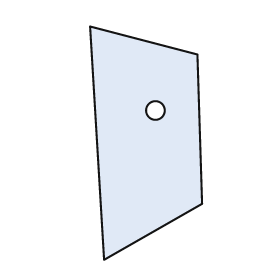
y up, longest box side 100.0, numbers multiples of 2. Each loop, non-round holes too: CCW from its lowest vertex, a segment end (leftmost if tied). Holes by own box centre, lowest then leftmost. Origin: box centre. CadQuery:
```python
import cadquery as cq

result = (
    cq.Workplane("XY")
    .moveTo(-18.0, -50.0)
    .lineTo(24.0, -26.0)
    .lineTo(22.0, 38.0)
    .lineTo(-24.0, 50.0)
    .close()
    .moveTo(4.0, 14.0)
    .circle(4.0)
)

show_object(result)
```